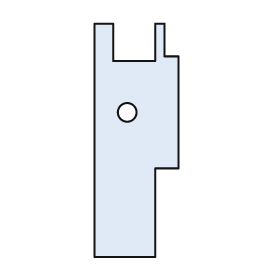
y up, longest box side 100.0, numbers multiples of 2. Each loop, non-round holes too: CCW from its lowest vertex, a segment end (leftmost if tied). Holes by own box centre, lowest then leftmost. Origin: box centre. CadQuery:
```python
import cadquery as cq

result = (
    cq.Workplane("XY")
    .moveTo(-18.0, -50.0)
    .lineTo(8.0, -50.0)
    .lineTo(8.0, -12.0)
    .lineTo(18.0, -12.0)
    .lineTo(18.0, 36.0)
    .lineTo(12.0, 36.0)
    .lineTo(12.0, 50.0)
    .lineTo(8.0, 50.0)
    .lineTo(8.0, 34.0)
    .lineTo(-10.0, 34.0)
    .lineTo(-10.0, 50.0)
    .lineTo(-18.0, 50.0)
    .close()
    .moveTo(-4.0, 12.0)
    .circle(4.0)
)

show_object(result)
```